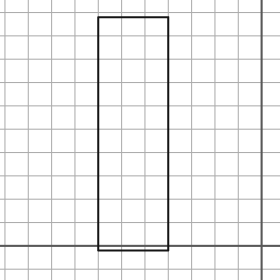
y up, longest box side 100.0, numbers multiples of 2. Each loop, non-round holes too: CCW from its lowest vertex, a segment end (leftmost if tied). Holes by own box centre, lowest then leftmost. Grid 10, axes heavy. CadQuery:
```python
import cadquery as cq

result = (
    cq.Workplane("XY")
    .moveTo(-70.0, -2.0)
    .lineTo(-40.0, -2.0)
    .lineTo(-40.0, 98.0)
    .lineTo(-70.0, 98.0)
    .close()
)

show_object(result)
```